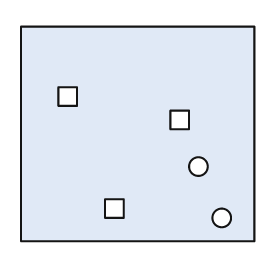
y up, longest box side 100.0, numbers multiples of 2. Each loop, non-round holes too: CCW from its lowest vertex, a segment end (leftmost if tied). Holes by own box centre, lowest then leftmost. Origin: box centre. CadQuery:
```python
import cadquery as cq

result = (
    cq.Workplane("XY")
    .moveTo(-50.0, -46.0)
    .lineTo(50.0, -46.0)
    .lineTo(50.0, 46.0)
    .lineTo(-50.0, 46.0)
    .close()
    .moveTo(36.0, -36.0)
    .circle(4.0)
    .moveTo(-14.0, -36.0)
    .lineTo(-6.0, -36.0)
    .lineTo(-6.0, -28.0)
    .lineTo(-14.0, -28.0)
    .close()
    .moveTo(26.0, -14.0)
    .circle(4.0)
    .moveTo(14.0, 2.0)
    .lineTo(22.0, 2.0)
    .lineTo(22.0, 10.0)
    .lineTo(14.0, 10.0)
    .close()
    .moveTo(-34.0, 12.0)
    .lineTo(-26.0, 12.0)
    .lineTo(-26.0, 20.0)
    .lineTo(-34.0, 20.0)
    .close()
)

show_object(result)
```